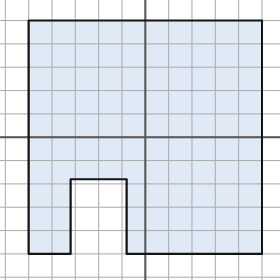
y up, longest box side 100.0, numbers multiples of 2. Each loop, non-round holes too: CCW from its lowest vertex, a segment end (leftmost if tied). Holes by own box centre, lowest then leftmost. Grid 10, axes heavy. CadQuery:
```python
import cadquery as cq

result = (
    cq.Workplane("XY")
    .moveTo(-50.0, -50.0)
    .lineTo(-32.0, -50.0)
    .lineTo(-32.0, -18.0)
    .lineTo(-8.0, -18.0)
    .lineTo(-8.0, -50.0)
    .lineTo(50.0, -50.0)
    .lineTo(50.0, 50.0)
    .lineTo(-50.0, 50.0)
    .close()
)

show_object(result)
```